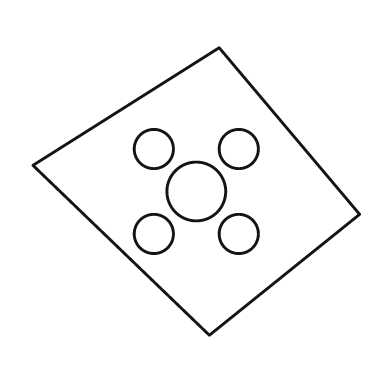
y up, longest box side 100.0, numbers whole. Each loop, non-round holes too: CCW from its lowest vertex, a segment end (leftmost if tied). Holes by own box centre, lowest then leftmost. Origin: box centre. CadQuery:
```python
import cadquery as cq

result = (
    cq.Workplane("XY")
    .moveTo(4.0, -44.0)
    .lineTo(50.0, -7.0)
    .lineTo(7.0, 44.0)
    .lineTo(-50.0, 8.0)
    .close()
    .moveTo(-13.0, -13.0)
    .circle(6.0)
    .moveTo(13.0, -13.0)
    .circle(6.0)
    .moveTo(0.0, 0.0)
    .circle(9.0)
    .moveTo(-13.0, 13.0)
    .circle(6.0)
    .moveTo(13.0, 13.0)
    .circle(6.0)
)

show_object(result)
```